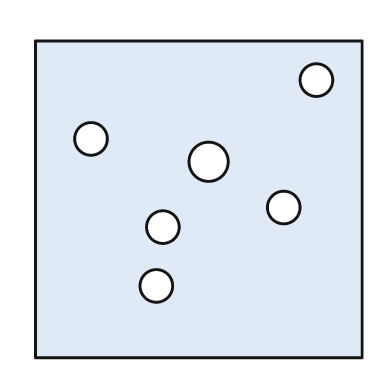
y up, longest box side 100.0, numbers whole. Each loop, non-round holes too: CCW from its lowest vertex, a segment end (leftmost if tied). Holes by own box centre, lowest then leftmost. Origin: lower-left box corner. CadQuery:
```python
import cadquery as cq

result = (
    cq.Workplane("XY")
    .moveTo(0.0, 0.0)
    .lineTo(100.0, 0.0)
    .lineTo(100.0, 97.0)
    .lineTo(0.0, 97.0)
    .close()
    .moveTo(37.0, 22.0)
    .circle(5.0)
    .moveTo(39.0, 40.0)
    .circle(5.0)
    .moveTo(76.0, 46.0)
    .circle(5.0)
    .moveTo(53.0, 60.0)
    .circle(6.0)
    .moveTo(17.0, 67.0)
    .circle(5.0)
    .moveTo(86.0, 85.0)
    .circle(5.0)
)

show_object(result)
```